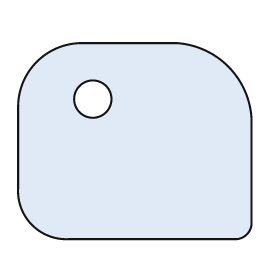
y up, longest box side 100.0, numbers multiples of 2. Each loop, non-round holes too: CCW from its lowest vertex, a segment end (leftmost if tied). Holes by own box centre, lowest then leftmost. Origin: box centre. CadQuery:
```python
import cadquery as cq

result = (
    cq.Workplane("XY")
    .moveTo(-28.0, -42.0)
    .lineTo(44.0, -42.0)
    .threePointArc((48.0, -40.0), (50.0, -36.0))
    .lineTo(50.0, 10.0)
    .threePointArc((40.0, 32.0), (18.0, 42.0))
    .lineTo(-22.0, 42.0)
    .threePointArc((-42.0, 34.0), (-50.0, 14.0))
    .lineTo(-50.0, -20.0)
    .threePointArc((-44.0, -36.0), (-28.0, -42.0))
    .close()
    .moveTo(-18.0, 18.0)
    .circle(8.0)
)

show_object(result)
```